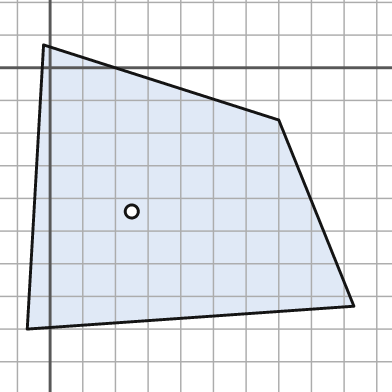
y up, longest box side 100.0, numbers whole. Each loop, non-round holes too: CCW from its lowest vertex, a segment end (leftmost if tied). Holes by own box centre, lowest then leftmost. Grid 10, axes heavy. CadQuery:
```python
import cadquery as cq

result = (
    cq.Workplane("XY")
    .moveTo(-7.0, -80.0)
    .lineTo(93.0, -73.0)
    .lineTo(70.0, -16.0)
    .lineTo(-2.0, 7.0)
    .close()
    .moveTo(25.0, -44.0)
    .circle(2.0)
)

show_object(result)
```